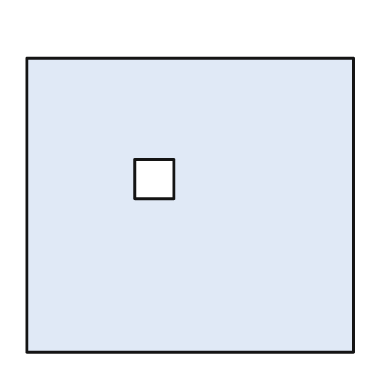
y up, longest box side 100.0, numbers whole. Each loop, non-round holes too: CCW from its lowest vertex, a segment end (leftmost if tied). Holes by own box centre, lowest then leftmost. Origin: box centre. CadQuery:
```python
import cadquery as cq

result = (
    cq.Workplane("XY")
    .moveTo(-50.0, -45.0)
    .lineTo(50.0, -45.0)
    .lineTo(50.0, 45.0)
    .lineTo(-50.0, 45.0)
    .close()
    .moveTo(-17.0, 2.0)
    .lineTo(-5.0, 2.0)
    .lineTo(-5.0, 14.0)
    .lineTo(-17.0, 14.0)
    .close()
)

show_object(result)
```